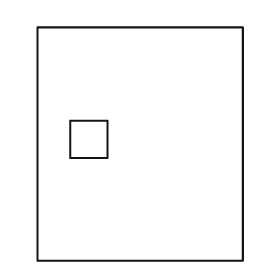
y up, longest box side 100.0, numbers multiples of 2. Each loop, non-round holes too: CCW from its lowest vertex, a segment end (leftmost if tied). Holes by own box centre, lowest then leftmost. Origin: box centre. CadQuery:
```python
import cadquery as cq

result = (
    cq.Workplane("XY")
    .moveTo(-44.0, -50.0)
    .lineTo(44.0, -50.0)
    .lineTo(44.0, 50.0)
    .lineTo(-44.0, 50.0)
    .close()
    .moveTo(-30.0, -6.0)
    .lineTo(-14.0, -6.0)
    .lineTo(-14.0, 10.0)
    .lineTo(-30.0, 10.0)
    .close()
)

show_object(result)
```